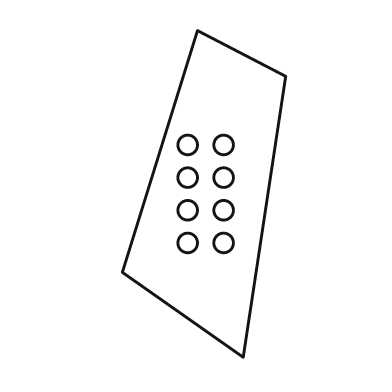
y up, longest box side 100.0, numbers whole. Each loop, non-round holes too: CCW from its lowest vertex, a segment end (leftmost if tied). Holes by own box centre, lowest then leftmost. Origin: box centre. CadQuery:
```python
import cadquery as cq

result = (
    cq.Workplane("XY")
    .moveTo(12.0, -50.0)
    .lineTo(25.0, 36.0)
    .lineTo(-2.0, 50.0)
    .lineTo(-25.0, -24.0)
    .close()
    .moveTo(-5.0, -15.0)
    .circle(3.0)
    .moveTo(6.0, -15.0)
    .circle(3.0)
    .moveTo(-5.0, -5.0)
    .circle(3.0)
    .moveTo(6.0, -5.0)
    .circle(3.0)
    .moveTo(-5.0, 5.0)
    .circle(3.0)
    .moveTo(6.0, 5.0)
    .circle(3.0)
    .moveTo(-5.0, 15.0)
    .circle(3.0)
    .moveTo(6.0, 15.0)
    .circle(3.0)
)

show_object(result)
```